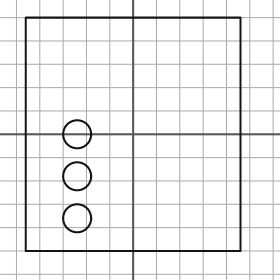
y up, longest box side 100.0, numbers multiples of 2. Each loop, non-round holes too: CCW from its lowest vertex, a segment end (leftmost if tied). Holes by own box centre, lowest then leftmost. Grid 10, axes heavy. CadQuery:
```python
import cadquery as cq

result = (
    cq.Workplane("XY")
    .moveTo(-46.0, -50.0)
    .lineTo(46.0, -50.0)
    .lineTo(46.0, 50.0)
    .lineTo(-46.0, 50.0)
    .close()
    .moveTo(-24.0, -36.0)
    .circle(6.0)
    .moveTo(-24.0, -18.0)
    .circle(6.0)
    .moveTo(-24.0, 0.0)
    .circle(6.0)
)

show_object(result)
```